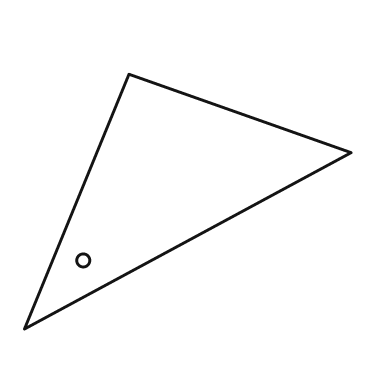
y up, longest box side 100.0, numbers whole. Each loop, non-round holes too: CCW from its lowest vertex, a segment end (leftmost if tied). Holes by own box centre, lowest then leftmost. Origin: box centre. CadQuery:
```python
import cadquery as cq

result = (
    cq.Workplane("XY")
    .moveTo(-50.0, -39.0)
    .lineTo(50.0, 15.0)
    .lineTo(-18.0, 39.0)
    .close()
    .moveTo(-32.0, -18.0)
    .circle(2.0)
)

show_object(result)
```